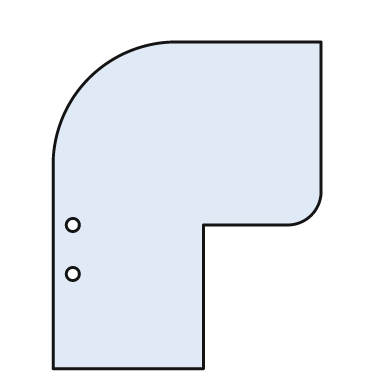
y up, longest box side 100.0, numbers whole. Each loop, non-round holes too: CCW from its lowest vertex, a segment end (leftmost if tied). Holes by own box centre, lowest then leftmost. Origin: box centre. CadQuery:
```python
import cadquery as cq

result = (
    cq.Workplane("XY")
    .moveTo(-41.0, -50.0)
    .lineTo(5.0, -50.0)
    .lineTo(5.0, -6.0)
    .lineTo(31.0, -6.0)
    .threePointArc((38.0, -3.0), (41.0, 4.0))
    .lineTo(41.0, 50.0)
    .lineTo(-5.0, 50.0)
    .threePointArc((-30.0, 39.0), (-41.0, 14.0))
    .close()
    .moveTo(-35.0, -21.0)
    .circle(2.0)
    .moveTo(-35.0, -6.0)
    .circle(2.0)
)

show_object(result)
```